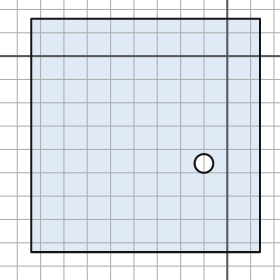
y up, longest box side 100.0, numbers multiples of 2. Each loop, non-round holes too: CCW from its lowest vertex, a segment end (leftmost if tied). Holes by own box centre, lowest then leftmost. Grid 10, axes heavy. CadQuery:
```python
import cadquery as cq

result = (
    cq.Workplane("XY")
    .moveTo(-84.0, -84.0)
    .lineTo(14.0, -84.0)
    .lineTo(14.0, 16.0)
    .lineTo(-84.0, 16.0)
    .close()
    .moveTo(-10.0, -46.0)
    .circle(4.0)
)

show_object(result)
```